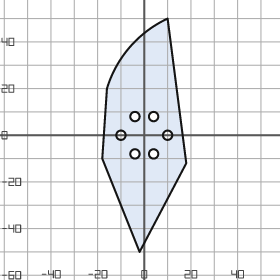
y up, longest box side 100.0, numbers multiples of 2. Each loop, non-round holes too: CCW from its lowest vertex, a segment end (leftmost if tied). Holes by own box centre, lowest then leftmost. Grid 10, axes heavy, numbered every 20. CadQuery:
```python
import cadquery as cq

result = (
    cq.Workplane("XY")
    .moveTo(-2.0, -50.0)
    .lineTo(18.0, -12.0)
    .lineTo(10.0, 50.0)
    .threePointArc((-6.0, 38.0), (-16.0, 20.0))
    .lineTo(-18.0, -10.0)
    .close()
    .moveTo(-4.0, -8.0)
    .circle(2.0)
    .moveTo(4.0, -8.0)
    .circle(2.0)
    .moveTo(-10.0, 0.0)
    .circle(2.0)
    .moveTo(10.0, 0.0)
    .circle(2.0)
    .moveTo(-4.0, 8.0)
    .circle(2.0)
    .moveTo(4.0, 8.0)
    .circle(2.0)
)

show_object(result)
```